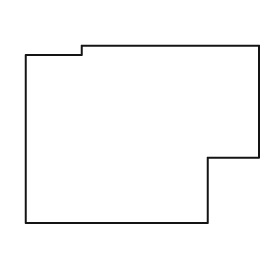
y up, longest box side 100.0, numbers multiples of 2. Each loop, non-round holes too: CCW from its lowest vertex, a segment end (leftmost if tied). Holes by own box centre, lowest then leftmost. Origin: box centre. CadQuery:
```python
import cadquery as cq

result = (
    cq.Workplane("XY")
    .moveTo(-50.0, -38.0)
    .lineTo(28.0, -38.0)
    .lineTo(28.0, -10.0)
    .lineTo(50.0, -10.0)
    .lineTo(50.0, 38.0)
    .lineTo(-26.0, 38.0)
    .lineTo(-26.0, 34.0)
    .lineTo(-50.0, 34.0)
    .close()
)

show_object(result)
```